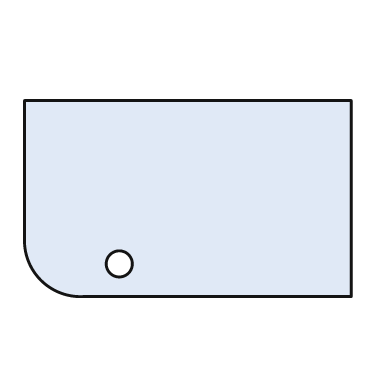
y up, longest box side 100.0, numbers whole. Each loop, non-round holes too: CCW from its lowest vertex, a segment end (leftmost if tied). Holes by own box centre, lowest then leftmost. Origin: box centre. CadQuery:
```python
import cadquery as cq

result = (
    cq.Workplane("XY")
    .moveTo(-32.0, -30.0)
    .lineTo(50.0, -30.0)
    .lineTo(50.0, 30.0)
    .lineTo(-50.0, 30.0)
    .lineTo(-50.0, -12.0)
    .threePointArc((-45.0, -25.0), (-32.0, -30.0))
    .close()
    .moveTo(-21.0, -20.0)
    .circle(4.0)
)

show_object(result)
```